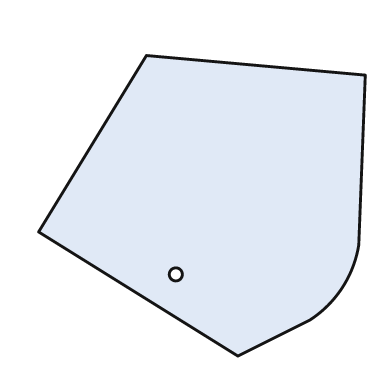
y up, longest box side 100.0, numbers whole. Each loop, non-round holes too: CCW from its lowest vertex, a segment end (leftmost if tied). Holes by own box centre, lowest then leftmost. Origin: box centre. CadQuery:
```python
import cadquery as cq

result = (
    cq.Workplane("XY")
    .moveTo(11.0, -46.0)
    .lineTo(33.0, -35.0)
    .threePointArc((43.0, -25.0), (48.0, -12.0))
    .lineTo(50.0, 40.0)
    .lineTo(-17.0, 46.0)
    .lineTo(-50.0, -8.0)
    .close()
    .moveTo(-8.0, -21.0)
    .circle(2.0)
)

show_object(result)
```